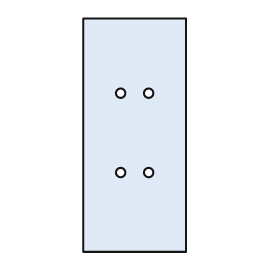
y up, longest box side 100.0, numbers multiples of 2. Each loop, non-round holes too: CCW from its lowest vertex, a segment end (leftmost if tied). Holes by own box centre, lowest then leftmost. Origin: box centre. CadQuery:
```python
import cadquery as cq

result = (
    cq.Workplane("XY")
    .moveTo(-22.0, -50.0)
    .lineTo(22.0, -50.0)
    .lineTo(22.0, 50.0)
    .lineTo(-22.0, 50.0)
    .close()
    .moveTo(-6.0, -16.0)
    .circle(2.0)
    .moveTo(6.0, -16.0)
    .circle(2.0)
    .moveTo(-6.0, 18.0)
    .circle(2.0)
    .moveTo(6.0, 18.0)
    .circle(2.0)
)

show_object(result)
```